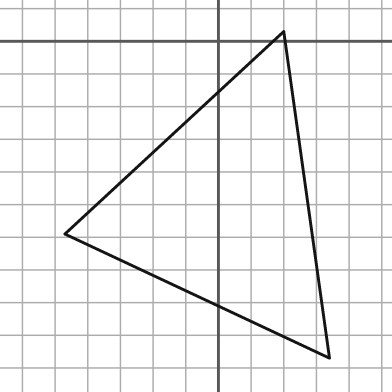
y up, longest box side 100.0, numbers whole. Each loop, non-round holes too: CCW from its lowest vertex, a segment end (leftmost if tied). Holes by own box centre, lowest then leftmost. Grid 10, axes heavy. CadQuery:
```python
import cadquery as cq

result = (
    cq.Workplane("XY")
    .moveTo(34.0, -97.0)
    .lineTo(20.0, 3.0)
    .lineTo(-47.0, -59.0)
    .close()
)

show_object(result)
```